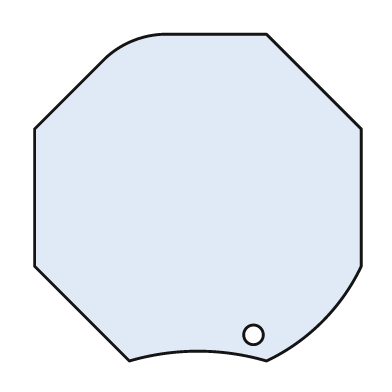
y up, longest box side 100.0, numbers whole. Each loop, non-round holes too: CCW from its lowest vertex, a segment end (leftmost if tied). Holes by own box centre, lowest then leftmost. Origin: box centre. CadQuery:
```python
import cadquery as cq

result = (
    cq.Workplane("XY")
    .moveTo(-21.0, -50.0)
    .threePointArc((0.0, -47.0), (21.0, -50.0))
    .threePointArc((38.0, -38.0), (50.0, -21.0))
    .lineTo(50.0, 21.0)
    .lineTo(21.0, 50.0)
    .lineTo(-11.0, 50.0)
    .threePointArc((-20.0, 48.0), (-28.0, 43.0))
    .lineTo(-50.0, 21.0)
    .lineTo(-50.0, -21.0)
    .close()
    .moveTo(17.0, -42.0)
    .circle(3.0)
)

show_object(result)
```